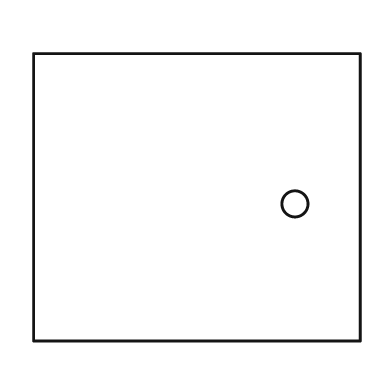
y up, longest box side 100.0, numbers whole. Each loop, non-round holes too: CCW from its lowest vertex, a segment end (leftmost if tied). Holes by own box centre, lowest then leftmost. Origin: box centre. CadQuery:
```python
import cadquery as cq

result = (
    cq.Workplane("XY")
    .moveTo(-50.0, -44.0)
    .lineTo(50.0, -44.0)
    .lineTo(50.0, 44.0)
    .lineTo(-50.0, 44.0)
    .close()
    .moveTo(30.0, -2.0)
    .circle(4.0)
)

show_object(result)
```